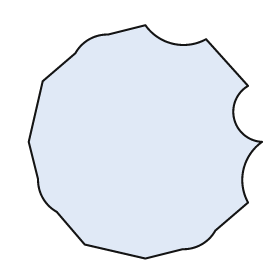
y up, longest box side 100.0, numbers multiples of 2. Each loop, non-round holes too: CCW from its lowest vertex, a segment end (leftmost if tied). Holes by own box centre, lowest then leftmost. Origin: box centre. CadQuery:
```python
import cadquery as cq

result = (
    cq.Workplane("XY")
    .moveTo(0.0, -50.0)
    .lineTo(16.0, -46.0)
    .threePointArc((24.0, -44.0), (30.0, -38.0))
    .lineTo(44.0, -26.0)
    .threePointArc((42.0, -12.0), (50.0, 0.0))
    .threePointArc((38.0, 10.0), (44.0, 24.0))
    .lineTo(26.0, 44.0)
    .threePointArc((12.0, 42.0), (0.0, 50.0))
    .lineTo(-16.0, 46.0)
    .threePointArc((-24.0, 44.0), (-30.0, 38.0))
    .lineTo(-44.0, 26.0)
    .lineTo(-50.0, 0.0)
    .lineTo(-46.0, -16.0)
    .threePointArc((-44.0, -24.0), (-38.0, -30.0))
    .lineTo(-26.0, -44.0)
    .close()
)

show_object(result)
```